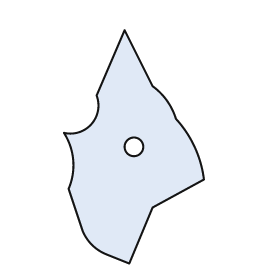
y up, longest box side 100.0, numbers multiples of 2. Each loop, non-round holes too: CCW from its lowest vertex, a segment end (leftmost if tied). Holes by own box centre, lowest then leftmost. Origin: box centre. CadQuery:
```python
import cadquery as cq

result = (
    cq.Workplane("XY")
    .moveTo(-2.0, -50.0)
    .lineTo(8.0, -26.0)
    .lineTo(30.0, -14.0)
    .threePointArc((26.0, 0.0), (18.0, 12.0))
    .threePointArc((14.0, 20.0), (8.0, 26.0))
    .lineTo(-4.0, 50.0)
    .lineTo(-16.0, 22.0)
    .threePointArc((-18.0, 10.0), (-30.0, 6.0))
    .threePointArc((-26.0, -6.0), (-28.0, -18.0))
    .lineTo(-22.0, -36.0)
    .threePointArc((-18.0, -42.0), (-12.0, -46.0))
    .close()
    .moveTo(0.0, 0.0)
    .circle(4.0)
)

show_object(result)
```